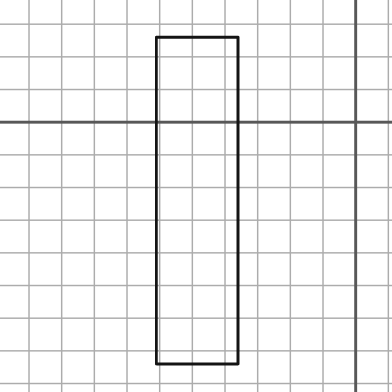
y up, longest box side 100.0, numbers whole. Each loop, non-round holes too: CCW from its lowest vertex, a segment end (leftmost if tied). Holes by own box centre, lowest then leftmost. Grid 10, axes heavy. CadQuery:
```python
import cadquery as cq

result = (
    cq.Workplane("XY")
    .moveTo(-61.0, -74.0)
    .lineTo(-36.0, -74.0)
    .lineTo(-36.0, 26.0)
    .lineTo(-61.0, 26.0)
    .close()
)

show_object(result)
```